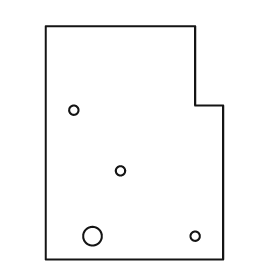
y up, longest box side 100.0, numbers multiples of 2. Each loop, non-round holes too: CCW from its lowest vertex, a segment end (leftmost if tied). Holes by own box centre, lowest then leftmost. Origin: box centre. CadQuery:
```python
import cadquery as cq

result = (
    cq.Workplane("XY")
    .moveTo(-38.0, -50.0)
    .lineTo(38.0, -50.0)
    .lineTo(38.0, 16.0)
    .lineTo(26.0, 16.0)
    .lineTo(26.0, 50.0)
    .lineTo(-38.0, 50.0)
    .close()
    .moveTo(-18.0, -40.0)
    .circle(4.0)
    .moveTo(26.0, -40.0)
    .circle(2.0)
    .moveTo(-6.0, -12.0)
    .circle(2.0)
    .moveTo(-26.0, 14.0)
    .circle(2.0)
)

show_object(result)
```